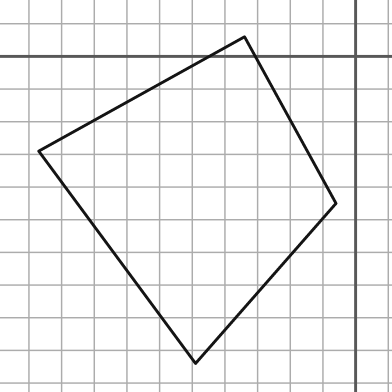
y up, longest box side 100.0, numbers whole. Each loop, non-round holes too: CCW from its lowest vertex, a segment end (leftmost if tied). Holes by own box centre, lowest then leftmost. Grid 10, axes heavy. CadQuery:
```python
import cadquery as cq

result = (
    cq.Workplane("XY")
    .moveTo(-49.0, -94.0)
    .lineTo(-6.0, -45.0)
    .lineTo(-34.0, 6.0)
    .lineTo(-97.0, -29.0)
    .close()
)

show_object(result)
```